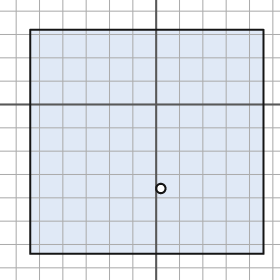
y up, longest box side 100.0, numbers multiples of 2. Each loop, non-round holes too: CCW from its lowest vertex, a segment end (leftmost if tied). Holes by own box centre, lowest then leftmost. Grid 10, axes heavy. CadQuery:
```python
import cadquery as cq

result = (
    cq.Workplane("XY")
    .moveTo(-54.0, -64.0)
    .lineTo(46.0, -64.0)
    .lineTo(46.0, 32.0)
    .lineTo(-54.0, 32.0)
    .close()
    .moveTo(2.0, -36.0)
    .circle(2.0)
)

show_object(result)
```